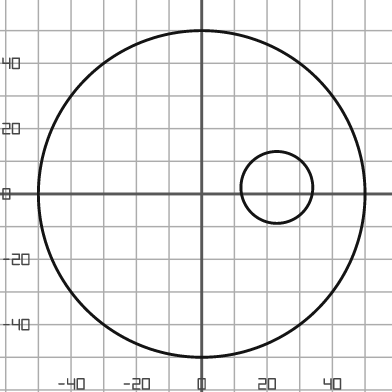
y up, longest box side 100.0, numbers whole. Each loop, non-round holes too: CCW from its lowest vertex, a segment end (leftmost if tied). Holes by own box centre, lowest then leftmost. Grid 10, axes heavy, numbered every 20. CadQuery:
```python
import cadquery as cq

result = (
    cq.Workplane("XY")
    .moveTo(0.0, 0.0)
    .circle(50.0)
    .moveTo(23.0, 2.0)
    .circle(11.0)
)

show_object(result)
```